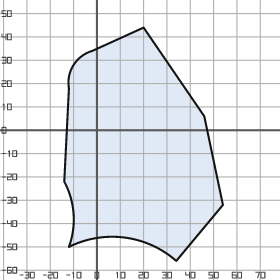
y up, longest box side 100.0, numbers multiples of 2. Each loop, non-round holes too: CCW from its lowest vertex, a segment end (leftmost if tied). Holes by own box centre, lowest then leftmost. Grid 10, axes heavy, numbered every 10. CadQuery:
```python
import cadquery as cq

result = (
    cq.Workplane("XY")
    .moveTo(34.0, -56.0)
    .lineTo(54.0, -32.0)
    .lineTo(46.0, 6.0)
    .lineTo(20.0, 44.0)
    .lineTo(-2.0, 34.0)
    .threePointArc((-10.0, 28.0), (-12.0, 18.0))
    .lineTo(-14.0, -22.0)
    .threePointArc((-10.0, -36.0), (-12.0, -50.0))
    .threePointArc((12.0, -46.0), (34.0, -56.0))
    .close()
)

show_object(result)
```